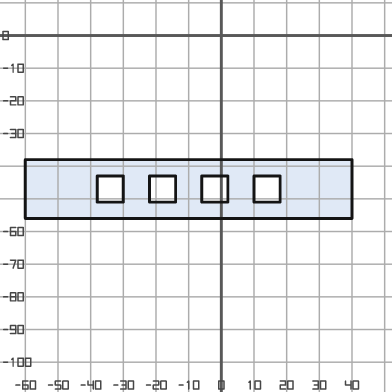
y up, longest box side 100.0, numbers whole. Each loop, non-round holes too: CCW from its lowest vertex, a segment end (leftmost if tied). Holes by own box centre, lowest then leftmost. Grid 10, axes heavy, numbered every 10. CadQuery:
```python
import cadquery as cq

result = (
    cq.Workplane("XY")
    .moveTo(-60.0, -56.0)
    .lineTo(40.0, -56.0)
    .lineTo(40.0, -38.0)
    .lineTo(-60.0, -38.0)
    .close()
    .moveTo(-38.0, -51.0)
    .lineTo(-30.0, -51.0)
    .lineTo(-30.0, -43.0)
    .lineTo(-38.0, -43.0)
    .close()
    .moveTo(-22.0, -51.0)
    .lineTo(-14.0, -51.0)
    .lineTo(-14.0, -43.0)
    .lineTo(-22.0, -43.0)
    .close()
    .moveTo(-6.0, -51.0)
    .lineTo(2.0, -51.0)
    .lineTo(2.0, -43.0)
    .lineTo(-6.0, -43.0)
    .close()
    .moveTo(10.0, -51.0)
    .lineTo(18.0, -51.0)
    .lineTo(18.0, -43.0)
    .lineTo(10.0, -43.0)
    .close()
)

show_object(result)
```